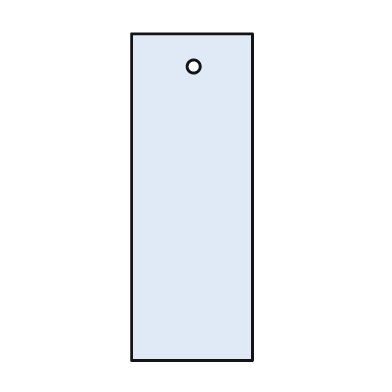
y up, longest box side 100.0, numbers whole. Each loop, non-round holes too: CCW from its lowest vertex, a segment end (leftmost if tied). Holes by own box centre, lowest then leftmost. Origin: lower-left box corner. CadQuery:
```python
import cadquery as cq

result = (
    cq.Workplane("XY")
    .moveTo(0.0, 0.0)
    .lineTo(37.0, 0.0)
    .lineTo(37.0, 100.0)
    .lineTo(0.0, 100.0)
    .close()
    .moveTo(19.0, 90.0)
    .circle(2.0)
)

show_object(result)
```